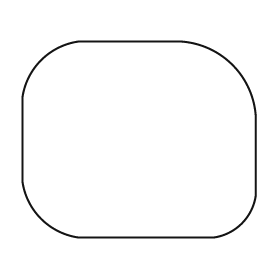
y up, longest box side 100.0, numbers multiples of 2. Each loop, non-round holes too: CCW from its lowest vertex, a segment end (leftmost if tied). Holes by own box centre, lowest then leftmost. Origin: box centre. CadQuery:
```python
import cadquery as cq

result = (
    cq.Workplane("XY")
    .moveTo(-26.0, -42.0)
    .lineTo(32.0, -42.0)
    .threePointArc((44.0, -36.0), (50.0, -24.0))
    .lineTo(50.0, 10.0)
    .threePointArc((40.0, 32.0), (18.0, 42.0))
    .lineTo(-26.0, 42.0)
    .threePointArc((-42.0, 34.0), (-50.0, 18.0))
    .lineTo(-50.0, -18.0)
    .threePointArc((-42.0, -34.0), (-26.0, -42.0))
    .close()
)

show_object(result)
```